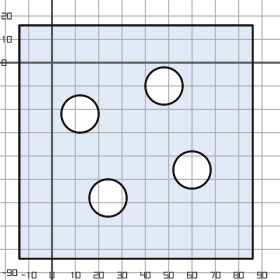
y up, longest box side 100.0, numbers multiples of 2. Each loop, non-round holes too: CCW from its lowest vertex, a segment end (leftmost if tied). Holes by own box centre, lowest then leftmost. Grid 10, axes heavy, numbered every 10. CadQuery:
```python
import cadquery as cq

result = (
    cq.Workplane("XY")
    .moveTo(-14.0, -84.0)
    .lineTo(86.0, -84.0)
    .lineTo(86.0, 16.0)
    .lineTo(-14.0, 16.0)
    .close()
    .moveTo(24.0, -58.0)
    .circle(8.0)
    .moveTo(60.0, -46.0)
    .circle(8.0)
    .moveTo(12.0, -22.0)
    .circle(8.0)
    .moveTo(48.0, -10.0)
    .circle(8.0)
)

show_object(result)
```